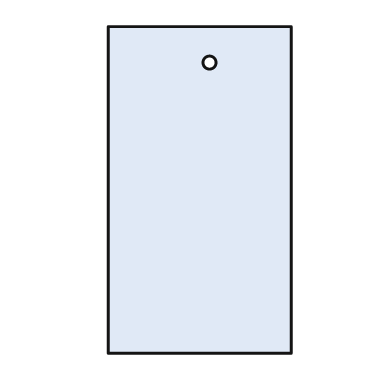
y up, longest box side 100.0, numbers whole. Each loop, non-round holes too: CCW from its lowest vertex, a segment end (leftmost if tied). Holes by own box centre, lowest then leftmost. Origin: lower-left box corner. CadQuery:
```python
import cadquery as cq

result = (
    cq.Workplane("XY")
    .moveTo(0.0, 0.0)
    .lineTo(56.0, 0.0)
    .lineTo(56.0, 100.0)
    .lineTo(0.0, 100.0)
    .close()
    .moveTo(31.0, 89.0)
    .circle(2.0)
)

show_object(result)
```